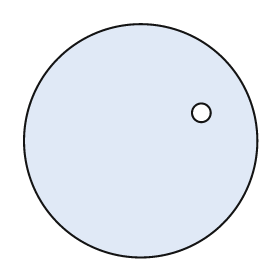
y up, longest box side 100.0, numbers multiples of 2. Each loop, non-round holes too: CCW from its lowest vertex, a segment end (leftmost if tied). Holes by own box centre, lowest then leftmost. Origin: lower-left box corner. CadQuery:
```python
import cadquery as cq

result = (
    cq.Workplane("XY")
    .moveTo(50.0, 50.0)
    .circle(50.0)
    .moveTo(76.0, 62.0)
    .circle(4.0)
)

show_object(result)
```